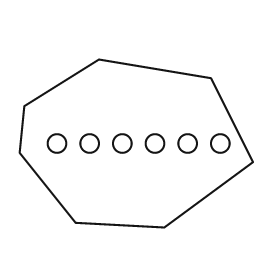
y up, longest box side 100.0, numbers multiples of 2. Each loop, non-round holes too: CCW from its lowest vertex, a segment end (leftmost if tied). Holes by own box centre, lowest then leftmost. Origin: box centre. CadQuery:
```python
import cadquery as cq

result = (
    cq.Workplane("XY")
    .moveTo(12.0, -36.0)
    .lineTo(50.0, -8.0)
    .lineTo(32.0, 28.0)
    .lineTo(-16.0, 36.0)
    .lineTo(-48.0, 16.0)
    .lineTo(-50.0, -4.0)
    .lineTo(-26.0, -34.0)
    .close()
    .moveTo(-34.0, 0.0)
    .circle(4.0)
    .moveTo(-20.0, 0.0)
    .circle(4.0)
    .moveTo(-6.0, 0.0)
    .circle(4.0)
    .moveTo(8.0, 0.0)
    .circle(4.0)
    .moveTo(22.0, 0.0)
    .circle(4.0)
    .moveTo(36.0, 0.0)
    .circle(4.0)
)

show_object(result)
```